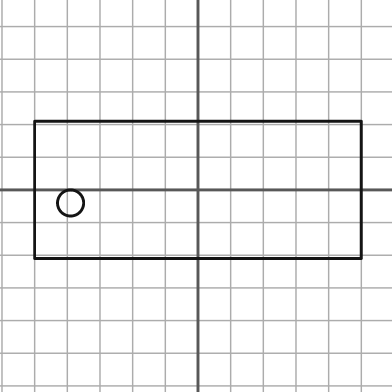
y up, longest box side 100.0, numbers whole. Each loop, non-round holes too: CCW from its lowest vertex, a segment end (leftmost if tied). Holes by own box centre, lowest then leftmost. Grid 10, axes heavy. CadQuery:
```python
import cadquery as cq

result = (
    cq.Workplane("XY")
    .moveTo(-50.0, -21.0)
    .lineTo(50.0, -21.0)
    .lineTo(50.0, 21.0)
    .lineTo(-50.0, 21.0)
    .close()
    .moveTo(-39.0, -4.0)
    .circle(4.0)
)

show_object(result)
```